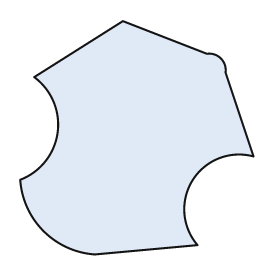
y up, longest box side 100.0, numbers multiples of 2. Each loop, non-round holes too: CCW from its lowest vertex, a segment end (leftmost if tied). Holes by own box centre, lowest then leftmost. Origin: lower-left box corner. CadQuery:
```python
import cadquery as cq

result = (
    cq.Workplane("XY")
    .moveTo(32.0, 0.0)
    .lineTo(76.0, 4.0)
    .threePointArc((74.0, 32.0), (100.0, 42.0))
    .lineTo(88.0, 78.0)
    .threePointArc((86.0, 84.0), (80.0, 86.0))
    .lineTo(44.0, 100.0)
    .lineTo(6.0, 76.0)
    .threePointArc((16.0, 52.0), (0.0, 32.0))
    .threePointArc((10.0, 10.0), (32.0, 0.0))
    .close()
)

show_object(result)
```